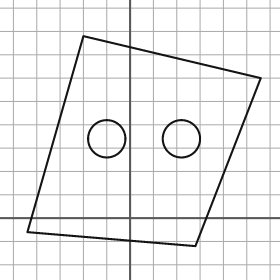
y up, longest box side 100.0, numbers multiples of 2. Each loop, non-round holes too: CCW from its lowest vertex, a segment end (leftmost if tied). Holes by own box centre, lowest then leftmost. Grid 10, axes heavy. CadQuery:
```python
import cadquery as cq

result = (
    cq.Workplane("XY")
    .moveTo(28.0, -12.0)
    .lineTo(56.0, 60.0)
    .lineTo(-20.0, 78.0)
    .lineTo(-44.0, -6.0)
    .close()
    .moveTo(-10.0, 34.0)
    .circle(8.0)
    .moveTo(22.0, 34.0)
    .circle(8.0)
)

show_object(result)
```